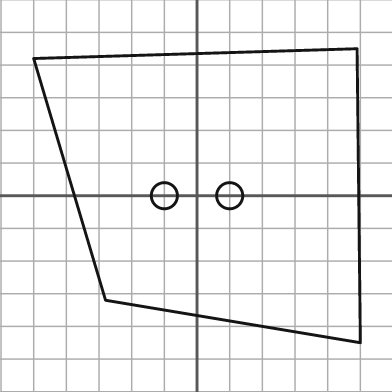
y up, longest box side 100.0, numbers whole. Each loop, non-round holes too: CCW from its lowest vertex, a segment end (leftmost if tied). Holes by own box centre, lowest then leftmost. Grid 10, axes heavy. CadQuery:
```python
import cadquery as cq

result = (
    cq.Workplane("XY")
    .moveTo(50.0, -45.0)
    .lineTo(49.0, 45.0)
    .lineTo(-50.0, 42.0)
    .lineTo(-28.0, -32.0)
    .close()
    .moveTo(-10.0, 0.0)
    .circle(4.0)
    .moveTo(10.0, 0.0)
    .circle(4.0)
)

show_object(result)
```